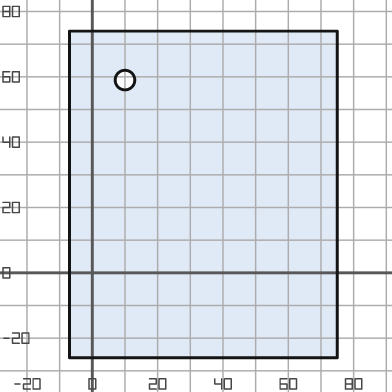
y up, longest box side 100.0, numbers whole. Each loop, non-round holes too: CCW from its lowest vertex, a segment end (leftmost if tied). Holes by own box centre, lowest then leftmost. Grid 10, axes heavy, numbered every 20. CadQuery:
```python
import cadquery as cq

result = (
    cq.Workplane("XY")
    .moveTo(-7.0, -26.0)
    .lineTo(75.0, -26.0)
    .lineTo(75.0, 74.0)
    .lineTo(-7.0, 74.0)
    .close()
    .moveTo(10.0, 59.0)
    .circle(3.0)
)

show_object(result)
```